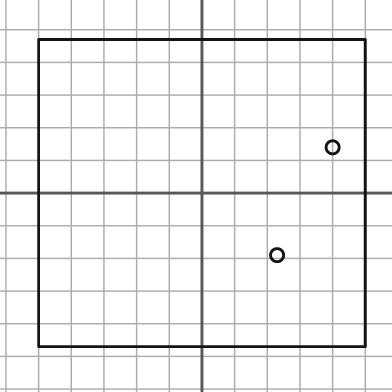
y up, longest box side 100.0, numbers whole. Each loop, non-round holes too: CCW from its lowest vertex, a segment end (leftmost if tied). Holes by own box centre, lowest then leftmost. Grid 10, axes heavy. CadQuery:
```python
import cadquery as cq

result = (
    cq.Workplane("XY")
    .moveTo(-50.0, -47.0)
    .lineTo(50.0, -47.0)
    .lineTo(50.0, 47.0)
    .lineTo(-50.0, 47.0)
    .close()
    .moveTo(23.0, -19.0)
    .circle(2.0)
    .moveTo(40.0, 14.0)
    .circle(2.0)
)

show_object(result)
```